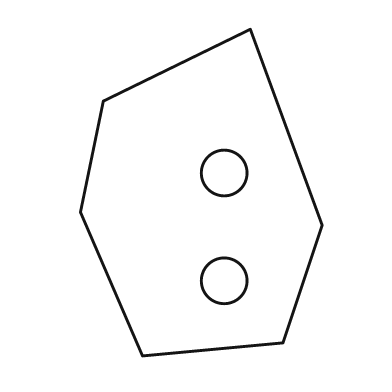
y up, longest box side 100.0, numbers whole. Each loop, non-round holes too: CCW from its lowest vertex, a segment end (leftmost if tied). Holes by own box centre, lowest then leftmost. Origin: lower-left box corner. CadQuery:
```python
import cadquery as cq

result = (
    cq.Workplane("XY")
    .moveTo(19.0, 0.0)
    .lineTo(62.0, 4.0)
    .lineTo(74.0, 40.0)
    .lineTo(52.0, 100.0)
    .lineTo(7.0, 78.0)
    .lineTo(0.0, 44.0)
    .close()
    .moveTo(44.0, 23.0)
    .circle(7.0)
    .moveTo(44.0, 56.0)
    .circle(7.0)
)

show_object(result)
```